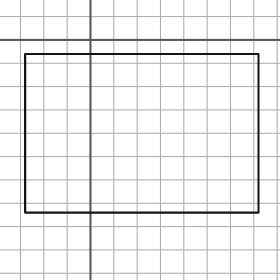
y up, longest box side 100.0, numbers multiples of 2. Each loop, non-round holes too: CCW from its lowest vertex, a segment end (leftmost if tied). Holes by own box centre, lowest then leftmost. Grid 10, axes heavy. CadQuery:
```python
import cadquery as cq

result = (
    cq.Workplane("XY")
    .moveTo(-28.0, -74.0)
    .lineTo(72.0, -74.0)
    .lineTo(72.0, -6.0)
    .lineTo(-28.0, -6.0)
    .close()
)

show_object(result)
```